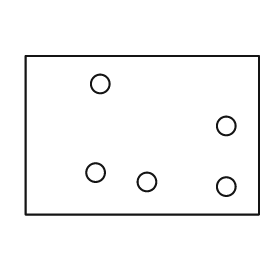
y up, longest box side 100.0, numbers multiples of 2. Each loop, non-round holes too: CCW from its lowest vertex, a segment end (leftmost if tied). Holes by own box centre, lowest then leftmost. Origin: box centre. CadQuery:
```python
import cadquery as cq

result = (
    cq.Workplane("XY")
    .moveTo(-50.0, -34.0)
    .lineTo(50.0, -34.0)
    .lineTo(50.0, 34.0)
    .lineTo(-50.0, 34.0)
    .close()
    .moveTo(36.0, -22.0)
    .circle(4.0)
    .moveTo(2.0, -20.0)
    .circle(4.0)
    .moveTo(-20.0, -16.0)
    .circle(4.0)
    .moveTo(36.0, 4.0)
    .circle(4.0)
    .moveTo(-18.0, 22.0)
    .circle(4.0)
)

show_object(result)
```